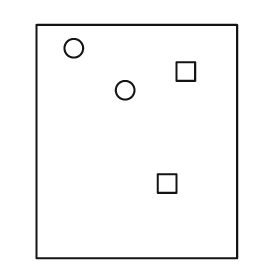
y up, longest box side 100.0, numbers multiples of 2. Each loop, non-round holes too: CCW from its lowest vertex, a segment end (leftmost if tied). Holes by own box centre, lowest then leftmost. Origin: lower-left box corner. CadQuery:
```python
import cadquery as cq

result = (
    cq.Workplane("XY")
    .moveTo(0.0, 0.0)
    .lineTo(86.0, 0.0)
    .lineTo(86.0, 100.0)
    .lineTo(0.0, 100.0)
    .close()
    .moveTo(52.0, 28.0)
    .lineTo(60.0, 28.0)
    .lineTo(60.0, 36.0)
    .lineTo(52.0, 36.0)
    .close()
    .moveTo(38.0, 72.0)
    .circle(4.0)
    .moveTo(60.0, 76.0)
    .lineTo(68.0, 76.0)
    .lineTo(68.0, 84.0)
    .lineTo(60.0, 84.0)
    .close()
    .moveTo(16.0, 90.0)
    .circle(4.0)
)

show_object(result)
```